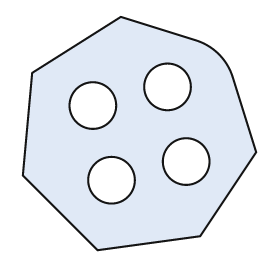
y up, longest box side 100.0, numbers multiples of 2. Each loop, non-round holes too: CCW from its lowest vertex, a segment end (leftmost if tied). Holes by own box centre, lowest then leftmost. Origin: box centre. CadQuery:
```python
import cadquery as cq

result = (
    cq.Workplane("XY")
    .moveTo(-18.0, -50.0)
    .lineTo(26.0, -44.0)
    .lineTo(50.0, -8.0)
    .lineTo(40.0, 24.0)
    .threePointArc((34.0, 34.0), (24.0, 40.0))
    .lineTo(-8.0, 50.0)
    .lineTo(-46.0, 26.0)
    .lineTo(-50.0, -18.0)
    .close()
    .moveTo(-12.0, -20.0)
    .circle(10.0)
    .moveTo(20.0, -12.0)
    .circle(10.0)
    .moveTo(-20.0, 12.0)
    .circle(10.0)
    .moveTo(12.0, 20.0)
    .circle(10.0)
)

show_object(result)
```